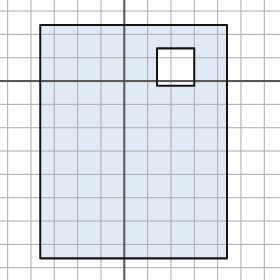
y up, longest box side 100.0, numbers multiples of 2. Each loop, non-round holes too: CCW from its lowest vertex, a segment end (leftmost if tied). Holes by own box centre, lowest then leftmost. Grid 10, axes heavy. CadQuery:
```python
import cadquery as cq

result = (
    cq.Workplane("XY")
    .moveTo(-36.0, -76.0)
    .lineTo(44.0, -76.0)
    .lineTo(44.0, 24.0)
    .lineTo(-36.0, 24.0)
    .close()
    .moveTo(14.0, -2.0)
    .lineTo(30.0, -2.0)
    .lineTo(30.0, 14.0)
    .lineTo(14.0, 14.0)
    .close()
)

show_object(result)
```